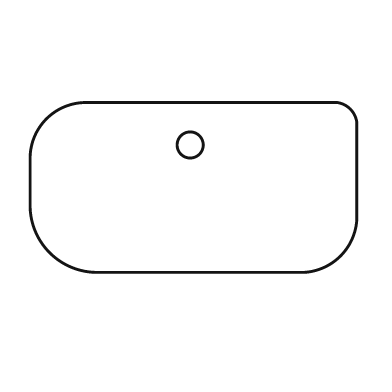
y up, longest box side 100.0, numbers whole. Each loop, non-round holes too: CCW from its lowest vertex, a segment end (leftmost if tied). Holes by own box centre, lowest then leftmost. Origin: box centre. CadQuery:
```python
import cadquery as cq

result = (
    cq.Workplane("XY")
    .moveTo(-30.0, -26.0)
    .lineTo(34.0, -26.0)
    .threePointArc((45.0, -21.0), (50.0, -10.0))
    .lineTo(50.0, 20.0)
    .threePointArc((48.0, 24.0), (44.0, 26.0))
    .lineTo(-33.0, 26.0)
    .threePointArc((-45.0, 21.0), (-50.0, 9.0))
    .lineTo(-50.0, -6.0)
    .threePointArc((-44.0, -20.0), (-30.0, -26.0))
    .close()
    .moveTo(-1.0, 13.0)
    .circle(4.0)
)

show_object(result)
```